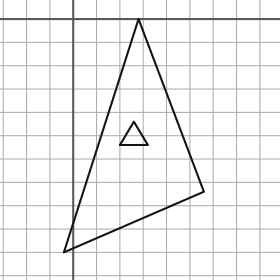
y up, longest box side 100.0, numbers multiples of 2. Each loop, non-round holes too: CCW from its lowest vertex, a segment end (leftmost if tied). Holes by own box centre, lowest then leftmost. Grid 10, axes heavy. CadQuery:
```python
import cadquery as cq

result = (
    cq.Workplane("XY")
    .moveTo(-4.0, -100.0)
    .lineTo(56.0, -74.0)
    .lineTo(28.0, 0.0)
    .close()
    .moveTo(20.0, -54.0)
    .lineTo(32.0, -54.0)
    .lineTo(26.0, -44.0)
    .close()
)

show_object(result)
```